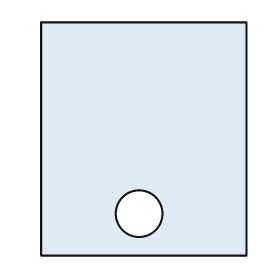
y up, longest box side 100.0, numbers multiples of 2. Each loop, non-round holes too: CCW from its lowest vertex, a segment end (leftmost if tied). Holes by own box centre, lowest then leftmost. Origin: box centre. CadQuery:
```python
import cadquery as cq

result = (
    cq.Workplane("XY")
    .moveTo(-44.0, -50.0)
    .lineTo(44.0, -50.0)
    .lineTo(44.0, 50.0)
    .lineTo(-44.0, 50.0)
    .close()
    .moveTo(-2.0, -32.0)
    .circle(10.0)
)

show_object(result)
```